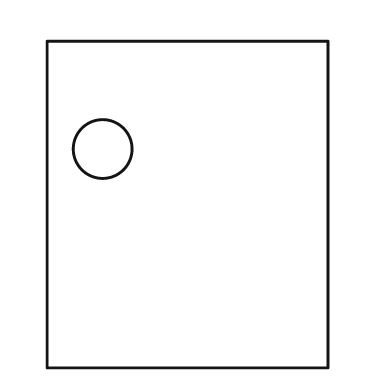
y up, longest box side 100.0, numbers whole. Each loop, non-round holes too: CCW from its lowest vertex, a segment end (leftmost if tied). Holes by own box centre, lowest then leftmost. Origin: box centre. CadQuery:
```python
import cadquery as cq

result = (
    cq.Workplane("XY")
    .moveTo(-43.0, -50.0)
    .lineTo(43.0, -50.0)
    .lineTo(43.0, 50.0)
    .lineTo(-43.0, 50.0)
    .close()
    .moveTo(-26.0, 17.0)
    .circle(9.0)
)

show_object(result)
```